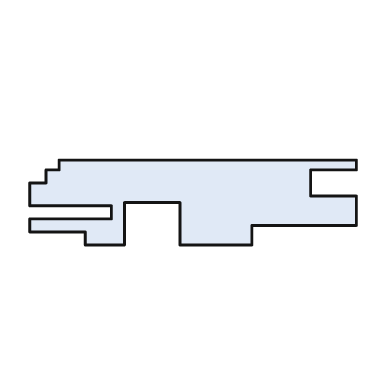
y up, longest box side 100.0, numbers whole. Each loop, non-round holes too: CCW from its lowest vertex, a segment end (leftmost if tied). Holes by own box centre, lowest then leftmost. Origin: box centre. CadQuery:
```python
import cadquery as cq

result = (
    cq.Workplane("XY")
    .moveTo(-33.0, -13.0)
    .lineTo(-21.0, -13.0)
    .lineTo(-21.0, 0.0)
    .lineTo(-4.0, 0.0)
    .lineTo(-4.0, -13.0)
    .lineTo(18.0, -13.0)
    .lineTo(18.0, -7.0)
    .lineTo(50.0, -7.0)
    .lineTo(50.0, 2.0)
    .lineTo(36.0, 2.0)
    .lineTo(36.0, 10.0)
    .lineTo(50.0, 10.0)
    .lineTo(50.0, 13.0)
    .lineTo(-41.0, 13.0)
    .lineTo(-41.0, 10.0)
    .lineTo(-45.0, 10.0)
    .lineTo(-45.0, 6.0)
    .lineTo(-50.0, 6.0)
    .lineTo(-50.0, -1.0)
    .lineTo(-25.0, -1.0)
    .lineTo(-25.0, -5.0)
    .lineTo(-50.0, -5.0)
    .lineTo(-50.0, -9.0)
    .lineTo(-33.0, -9.0)
    .close()
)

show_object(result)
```